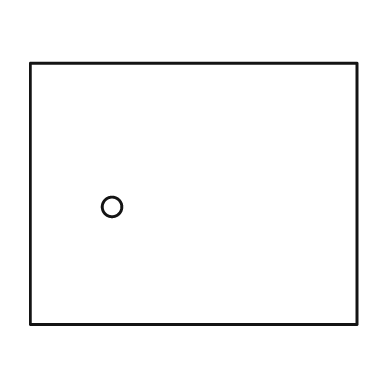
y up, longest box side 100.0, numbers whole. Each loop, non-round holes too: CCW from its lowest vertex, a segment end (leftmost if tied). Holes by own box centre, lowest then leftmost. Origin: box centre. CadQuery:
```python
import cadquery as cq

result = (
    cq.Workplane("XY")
    .moveTo(-50.0, -40.0)
    .lineTo(50.0, -40.0)
    .lineTo(50.0, 40.0)
    .lineTo(-50.0, 40.0)
    .close()
    .moveTo(-25.0, -4.0)
    .circle(3.0)
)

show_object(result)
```